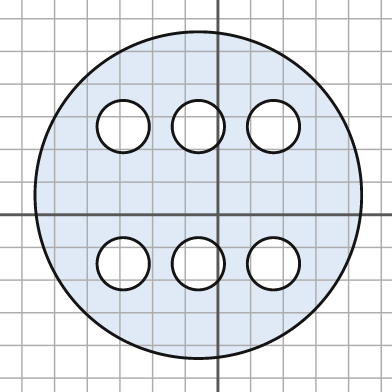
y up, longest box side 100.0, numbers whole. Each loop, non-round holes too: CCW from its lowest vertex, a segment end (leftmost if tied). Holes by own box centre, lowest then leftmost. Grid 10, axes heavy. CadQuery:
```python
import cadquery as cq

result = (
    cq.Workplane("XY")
    .moveTo(-6.0, 6.0)
    .circle(50.0)
    .moveTo(-29.0, -15.0)
    .circle(8.0)
    .moveTo(-6.0, -15.0)
    .circle(8.0)
    .moveTo(17.0, -15.0)
    .circle(8.0)
    .moveTo(-29.0, 27.0)
    .circle(8.0)
    .moveTo(-6.0, 27.0)
    .circle(8.0)
    .moveTo(17.0, 27.0)
    .circle(8.0)
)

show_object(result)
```